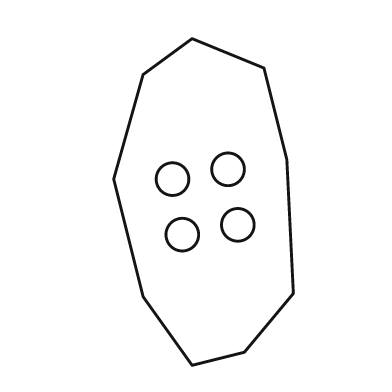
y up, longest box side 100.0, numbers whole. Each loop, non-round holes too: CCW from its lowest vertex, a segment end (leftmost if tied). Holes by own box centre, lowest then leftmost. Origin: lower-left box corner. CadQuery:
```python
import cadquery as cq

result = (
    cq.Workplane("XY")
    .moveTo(24.0, 0.0)
    .lineTo(40.0, 4.0)
    .lineTo(55.0, 22.0)
    .lineTo(53.0, 63.0)
    .lineTo(46.0, 91.0)
    .lineTo(24.0, 100.0)
    .lineTo(9.0, 89.0)
    .lineTo(0.0, 57.0)
    .lineTo(9.0, 21.0)
    .close()
    .moveTo(21.0, 40.0)
    .circle(5.0)
    .moveTo(38.0, 43.0)
    .circle(5.0)
    .moveTo(18.0, 57.0)
    .circle(5.0)
    .moveTo(35.0, 60.0)
    .circle(5.0)
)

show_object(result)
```